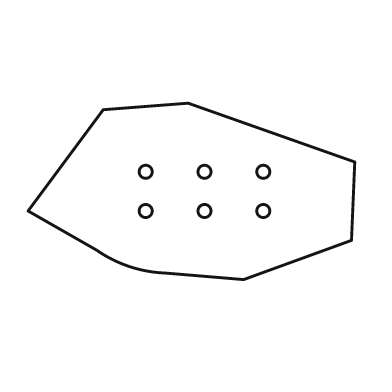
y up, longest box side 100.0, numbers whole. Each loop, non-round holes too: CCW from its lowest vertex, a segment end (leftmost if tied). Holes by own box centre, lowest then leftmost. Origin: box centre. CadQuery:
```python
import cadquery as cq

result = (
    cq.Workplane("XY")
    .moveTo(16.0, -27.0)
    .lineTo(49.0, -15.0)
    .lineTo(50.0, 9.0)
    .lineTo(-1.0, 27.0)
    .lineTo(-27.0, 25.0)
    .lineTo(-50.0, -6.0)
    .lineTo(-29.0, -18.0)
    .threePointArc((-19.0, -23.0), (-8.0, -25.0))
    .close()
    .moveTo(-14.0, -6.0)
    .circle(2.0)
    .moveTo(4.0, -6.0)
    .circle(2.0)
    .moveTo(22.0, -6.0)
    .circle(2.0)
    .moveTo(-14.0, 6.0)
    .circle(2.0)
    .moveTo(4.0, 6.0)
    .circle(2.0)
    .moveTo(22.0, 6.0)
    .circle(2.0)
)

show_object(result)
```